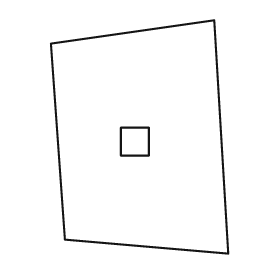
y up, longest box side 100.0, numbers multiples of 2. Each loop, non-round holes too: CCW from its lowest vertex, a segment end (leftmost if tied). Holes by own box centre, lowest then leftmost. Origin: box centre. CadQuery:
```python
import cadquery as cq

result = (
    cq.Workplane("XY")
    .moveTo(38.0, -50.0)
    .lineTo(32.0, 50.0)
    .lineTo(-38.0, 40.0)
    .lineTo(-32.0, -44.0)
    .close()
    .moveTo(-8.0, -8.0)
    .lineTo(4.0, -8.0)
    .lineTo(4.0, 4.0)
    .lineTo(-8.0, 4.0)
    .close()
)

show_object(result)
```